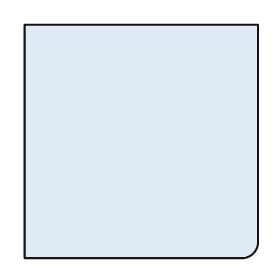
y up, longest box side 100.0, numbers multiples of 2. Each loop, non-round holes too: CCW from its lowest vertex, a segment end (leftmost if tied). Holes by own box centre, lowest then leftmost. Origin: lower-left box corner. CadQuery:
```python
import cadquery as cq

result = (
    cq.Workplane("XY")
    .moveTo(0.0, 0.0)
    .lineTo(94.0, 0.0)
    .threePointArc((98.0, 2.0), (100.0, 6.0))
    .lineTo(100.0, 100.0)
    .lineTo(0.0, 100.0)
    .close()
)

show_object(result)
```